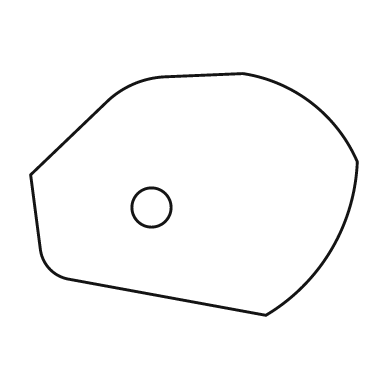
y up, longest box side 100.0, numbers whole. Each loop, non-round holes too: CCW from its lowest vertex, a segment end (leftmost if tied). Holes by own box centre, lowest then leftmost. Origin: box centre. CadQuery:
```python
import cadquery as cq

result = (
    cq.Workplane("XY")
    .moveTo(22.0, -37.0)
    .threePointArc((42.0, -17.0), (50.0, 10.0))
    .threePointArc((36.0, 28.0), (15.0, 37.0))
    .lineTo(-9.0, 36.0)
    .threePointArc((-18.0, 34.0), (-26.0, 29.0))
    .lineTo(-50.0, 6.0)
    .lineTo(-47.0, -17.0)
    .threePointArc((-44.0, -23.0), (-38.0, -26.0))
    .close()
    .moveTo(-13.0, -4.0)
    .circle(6.0)
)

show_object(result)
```